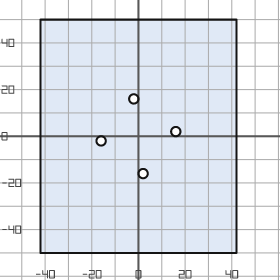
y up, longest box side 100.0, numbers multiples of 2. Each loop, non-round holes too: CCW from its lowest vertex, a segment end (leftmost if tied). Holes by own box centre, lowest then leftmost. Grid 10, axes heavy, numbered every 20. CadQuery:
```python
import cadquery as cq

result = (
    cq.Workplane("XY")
    .moveTo(-42.0, -50.0)
    .lineTo(42.0, -50.0)
    .lineTo(42.0, 50.0)
    .lineTo(-42.0, 50.0)
    .close()
    .moveTo(2.0, -16.0)
    .circle(2.0)
    .moveTo(-16.0, -2.0)
    .circle(2.0)
    .moveTo(16.0, 2.0)
    .circle(2.0)
    .moveTo(-2.0, 16.0)
    .circle(2.0)
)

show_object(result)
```